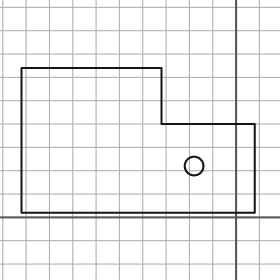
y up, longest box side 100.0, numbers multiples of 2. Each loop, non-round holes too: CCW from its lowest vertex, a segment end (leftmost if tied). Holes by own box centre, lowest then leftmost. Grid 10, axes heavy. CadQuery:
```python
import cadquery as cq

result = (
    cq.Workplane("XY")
    .moveTo(-92.0, 2.0)
    .lineTo(8.0, 2.0)
    .lineTo(8.0, 40.0)
    .lineTo(-32.0, 40.0)
    .lineTo(-32.0, 64.0)
    .lineTo(-92.0, 64.0)
    .close()
    .moveTo(-18.0, 22.0)
    .circle(4.0)
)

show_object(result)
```